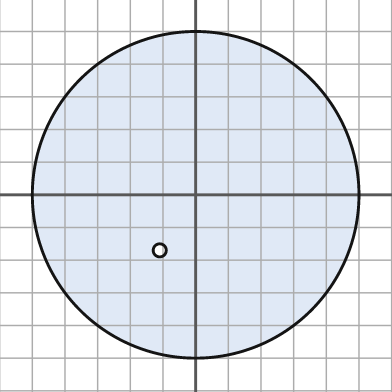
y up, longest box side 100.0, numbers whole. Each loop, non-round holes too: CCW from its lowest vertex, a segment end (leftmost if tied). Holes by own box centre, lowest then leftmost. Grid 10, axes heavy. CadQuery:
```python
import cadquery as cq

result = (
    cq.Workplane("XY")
    .moveTo(0.0, 0.0)
    .circle(50.0)
    .moveTo(-11.0, -17.0)
    .circle(2.0)
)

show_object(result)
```